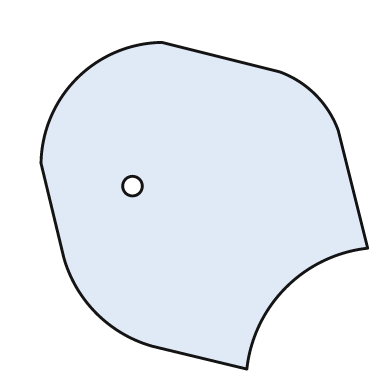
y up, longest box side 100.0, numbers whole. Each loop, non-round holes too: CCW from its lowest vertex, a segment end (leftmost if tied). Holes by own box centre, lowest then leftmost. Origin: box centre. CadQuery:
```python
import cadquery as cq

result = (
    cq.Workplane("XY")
    .moveTo(13.0, -50.0)
    .threePointArc((25.0, -25.0), (50.0, -13.0))
    .lineTo(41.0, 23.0)
    .threePointArc((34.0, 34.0), (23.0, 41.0))
    .lineTo(-13.0, 50.0)
    .threePointArc((-39.0, 39.0), (-50.0, 13.0))
    .lineTo(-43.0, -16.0)
    .threePointArc((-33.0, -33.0), (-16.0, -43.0))
    .close()
    .moveTo(-22.0, 6.0)
    .circle(3.0)
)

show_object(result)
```